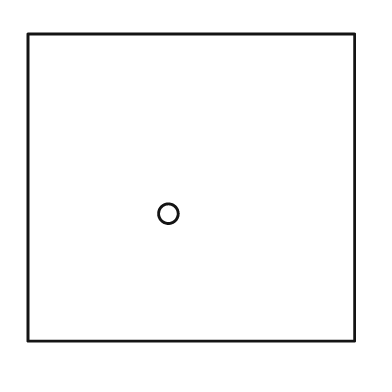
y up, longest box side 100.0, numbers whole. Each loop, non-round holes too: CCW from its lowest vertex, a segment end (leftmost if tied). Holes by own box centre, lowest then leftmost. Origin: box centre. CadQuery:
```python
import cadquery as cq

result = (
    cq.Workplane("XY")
    .moveTo(-50.0, -47.0)
    .lineTo(50.0, -47.0)
    .lineTo(50.0, 47.0)
    .lineTo(-50.0, 47.0)
    .close()
    .moveTo(-7.0, -8.0)
    .circle(3.0)
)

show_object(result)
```